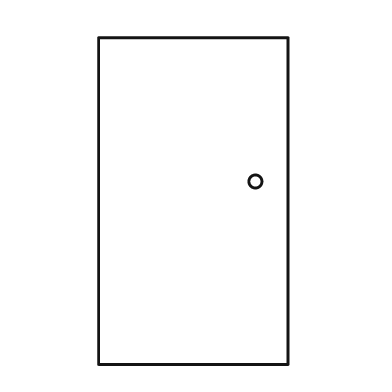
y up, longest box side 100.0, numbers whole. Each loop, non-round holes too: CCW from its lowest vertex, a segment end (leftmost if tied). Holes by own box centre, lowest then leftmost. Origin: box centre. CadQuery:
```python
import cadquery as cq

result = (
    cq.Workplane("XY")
    .moveTo(-29.0, -50.0)
    .lineTo(29.0, -50.0)
    .lineTo(29.0, 50.0)
    .lineTo(-29.0, 50.0)
    .close()
    .moveTo(19.0, 6.0)
    .circle(2.0)
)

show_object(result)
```